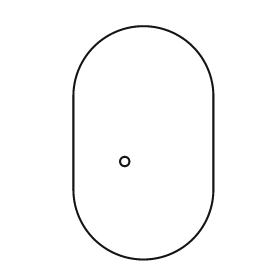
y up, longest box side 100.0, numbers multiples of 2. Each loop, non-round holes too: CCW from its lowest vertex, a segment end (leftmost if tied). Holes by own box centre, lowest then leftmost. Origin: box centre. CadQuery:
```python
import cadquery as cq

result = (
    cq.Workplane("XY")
    .moveTo(-30.0, -20.0)
    .threePointArc((0.0, -50.0), (30.0, -20.0))
    .lineTo(30.0, 20.0)
    .threePointArc((0.0, 50.0), (-30.0, 20.0))
    .close()
    .moveTo(-8.0, -8.0)
    .circle(2.0)
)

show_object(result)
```